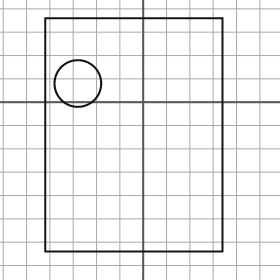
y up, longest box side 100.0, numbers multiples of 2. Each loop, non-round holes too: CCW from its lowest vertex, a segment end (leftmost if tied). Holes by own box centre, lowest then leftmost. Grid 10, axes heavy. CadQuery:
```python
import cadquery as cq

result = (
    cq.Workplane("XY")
    .moveTo(-42.0, -64.0)
    .lineTo(34.0, -64.0)
    .lineTo(34.0, 36.0)
    .lineTo(-42.0, 36.0)
    .close()
    .moveTo(-28.0, 8.0)
    .circle(10.0)
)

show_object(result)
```